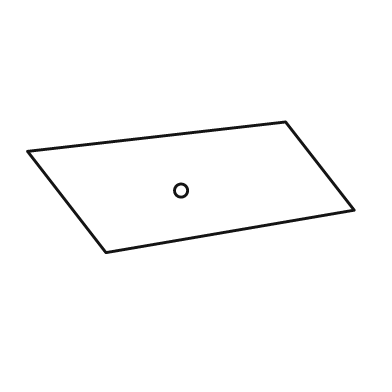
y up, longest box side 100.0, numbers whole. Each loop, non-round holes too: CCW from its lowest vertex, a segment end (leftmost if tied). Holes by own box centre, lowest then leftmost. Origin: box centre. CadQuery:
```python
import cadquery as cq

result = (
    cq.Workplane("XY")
    .moveTo(-26.0, -20.0)
    .lineTo(50.0, -7.0)
    .lineTo(29.0, 20.0)
    .lineTo(-50.0, 11.0)
    .close()
    .moveTo(-3.0, -1.0)
    .circle(2.0)
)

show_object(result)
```